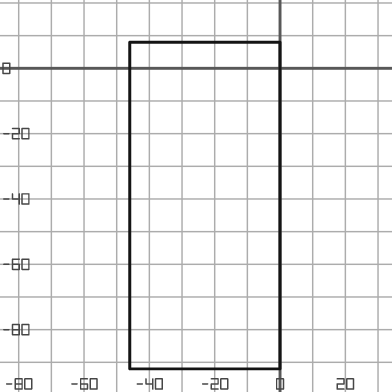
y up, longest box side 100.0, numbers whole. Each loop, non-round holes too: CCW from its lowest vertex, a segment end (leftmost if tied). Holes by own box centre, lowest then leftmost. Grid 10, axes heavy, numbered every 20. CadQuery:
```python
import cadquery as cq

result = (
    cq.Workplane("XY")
    .moveTo(-46.0, -92.0)
    .lineTo(0.0, -92.0)
    .lineTo(0.0, 8.0)
    .lineTo(-46.0, 8.0)
    .close()
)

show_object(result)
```